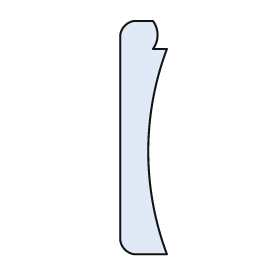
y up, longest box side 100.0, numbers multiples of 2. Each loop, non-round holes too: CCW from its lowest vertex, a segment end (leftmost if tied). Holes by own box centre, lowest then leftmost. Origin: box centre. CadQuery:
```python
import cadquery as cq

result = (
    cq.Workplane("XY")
    .moveTo(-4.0, -50.0)
    .lineTo(10.0, -50.0)
    .threePointArc((2.0, -6.0), (10.0, 38.0))
    .lineTo(4.0, 38.0)
    .threePointArc((6.0, 44.0), (4.0, 50.0))
    .lineTo(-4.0, 50.0)
    .threePointArc((-8.0, 48.0), (-10.0, 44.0))
    .lineTo(-10.0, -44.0)
    .threePointArc((-8.0, -48.0), (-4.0, -50.0))
    .close()
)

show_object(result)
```